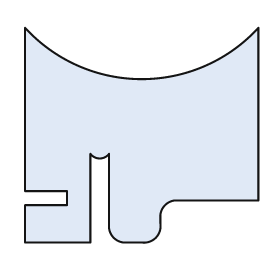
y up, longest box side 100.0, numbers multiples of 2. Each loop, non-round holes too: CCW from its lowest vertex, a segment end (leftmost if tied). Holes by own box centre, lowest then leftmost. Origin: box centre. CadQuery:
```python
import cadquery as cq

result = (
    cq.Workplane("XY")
    .moveTo(-50.0, -46.0)
    .lineTo(-22.0, -46.0)
    .lineTo(-22.0, -8.0)
    .threePointArc((-18.0, -10.0), (-14.0, -8.0))
    .lineTo(-14.0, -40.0)
    .threePointArc((-12.0, -44.0), (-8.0, -46.0))
    .lineTo(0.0, -46.0)
    .threePointArc((6.0, -44.0), (8.0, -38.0))
    .lineTo(8.0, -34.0)
    .threePointArc((10.0, -30.0), (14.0, -28.0))
    .lineTo(50.0, -28.0)
    .lineTo(50.0, 46.0)
    .threePointArc((0.0, 24.0), (-50.0, 46.0))
    .lineTo(-50.0, -24.0)
    .lineTo(-32.0, -24.0)
    .lineTo(-32.0, -30.0)
    .lineTo(-50.0, -30.0)
    .close()
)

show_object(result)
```